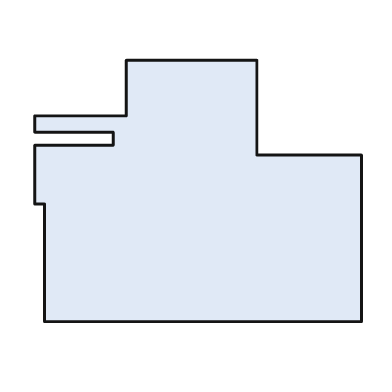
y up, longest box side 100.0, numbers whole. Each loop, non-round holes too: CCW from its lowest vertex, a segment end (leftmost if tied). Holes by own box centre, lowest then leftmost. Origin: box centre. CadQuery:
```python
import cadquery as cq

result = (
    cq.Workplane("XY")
    .moveTo(-47.0, -40.0)
    .lineTo(50.0, -40.0)
    .lineTo(50.0, 11.0)
    .lineTo(18.0, 11.0)
    .lineTo(18.0, 40.0)
    .lineTo(-22.0, 40.0)
    .lineTo(-22.0, 23.0)
    .lineTo(-50.0, 23.0)
    .lineTo(-50.0, 18.0)
    .lineTo(-26.0, 18.0)
    .lineTo(-26.0, 14.0)
    .lineTo(-50.0, 14.0)
    .lineTo(-50.0, -4.0)
    .lineTo(-47.0, -4.0)
    .close()
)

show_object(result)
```